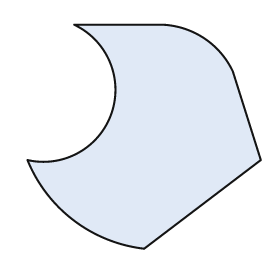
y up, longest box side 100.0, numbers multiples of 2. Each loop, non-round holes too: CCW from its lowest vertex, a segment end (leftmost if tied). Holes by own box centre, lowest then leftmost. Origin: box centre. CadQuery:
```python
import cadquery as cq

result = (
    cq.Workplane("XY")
    .moveTo(0.0, -48.0)
    .lineTo(50.0, -10.0)
    .lineTo(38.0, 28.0)
    .threePointArc((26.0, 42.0), (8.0, 48.0))
    .lineTo(-30.0, 48.0)
    .threePointArc((-14.0, 10.0), (-50.0, -10.0))
    .threePointArc((-30.0, -36.0), (0.0, -48.0))
    .close()
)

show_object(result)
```